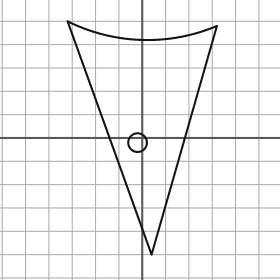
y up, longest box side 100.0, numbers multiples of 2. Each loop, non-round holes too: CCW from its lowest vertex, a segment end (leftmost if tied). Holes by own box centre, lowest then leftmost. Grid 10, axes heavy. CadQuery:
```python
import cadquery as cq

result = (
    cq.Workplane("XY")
    .moveTo(4.0, -50.0)
    .lineTo(32.0, 48.0)
    .threePointArc((0.0, 42.0), (-32.0, 50.0))
    .close()
    .moveTo(-2.0, -2.0)
    .circle(4.0)
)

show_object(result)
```